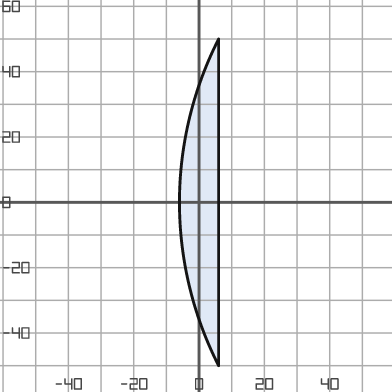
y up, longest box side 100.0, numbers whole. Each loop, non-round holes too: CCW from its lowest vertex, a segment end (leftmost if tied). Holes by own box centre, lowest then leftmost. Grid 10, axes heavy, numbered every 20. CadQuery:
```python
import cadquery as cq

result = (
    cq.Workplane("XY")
    .moveTo(6.0, -50.0)
    .lineTo(6.0, 50.0)
    .threePointArc((-6.0, 0.0), (6.0, -50.0))
    .close()
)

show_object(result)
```